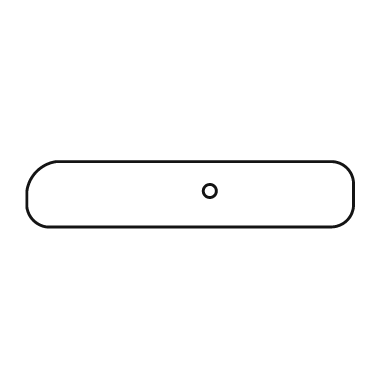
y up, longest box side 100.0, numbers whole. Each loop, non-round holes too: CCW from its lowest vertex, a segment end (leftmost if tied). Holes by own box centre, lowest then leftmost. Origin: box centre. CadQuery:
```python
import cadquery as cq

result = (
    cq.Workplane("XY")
    .moveTo(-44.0, -10.0)
    .lineTo(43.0, -10.0)
    .threePointArc((48.0, -8.0), (50.0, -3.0))
    .lineTo(50.0, 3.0)
    .threePointArc((48.0, 8.0), (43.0, 10.0))
    .lineTo(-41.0, 10.0)
    .threePointArc((-47.0, 7.0), (-50.0, 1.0))
    .lineTo(-50.0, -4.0)
    .threePointArc((-48.0, -8.0), (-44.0, -10.0))
    .close()
    .moveTo(6.0, 1.0)
    .circle(2.0)
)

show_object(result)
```